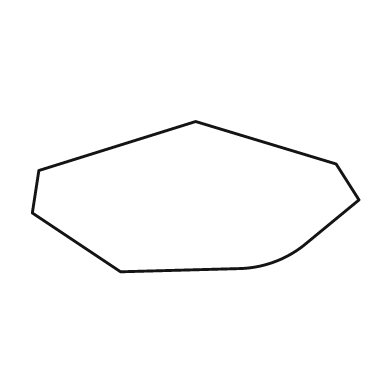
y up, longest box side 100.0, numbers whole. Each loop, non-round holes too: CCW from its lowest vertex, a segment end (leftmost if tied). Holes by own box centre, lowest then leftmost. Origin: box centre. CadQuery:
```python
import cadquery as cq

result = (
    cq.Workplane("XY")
    .moveTo(-23.0, -23.0)
    .lineTo(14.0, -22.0)
    .threePointArc((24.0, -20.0), (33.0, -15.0))
    .lineTo(50.0, -1.0)
    .lineTo(43.0, 10.0)
    .lineTo(0.0, 23.0)
    .lineTo(-48.0, 8.0)
    .lineTo(-50.0, -5.0)
    .close()
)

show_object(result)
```